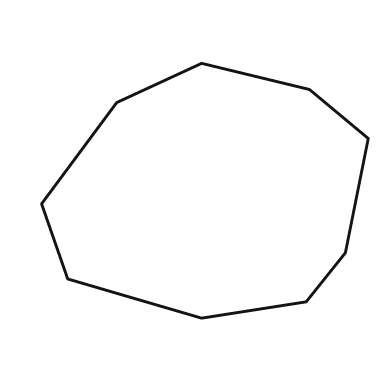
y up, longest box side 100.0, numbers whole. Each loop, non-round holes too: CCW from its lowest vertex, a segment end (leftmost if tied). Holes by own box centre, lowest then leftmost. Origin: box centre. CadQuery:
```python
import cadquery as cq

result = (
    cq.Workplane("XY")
    .moveTo(-1.0, -39.0)
    .lineTo(31.0, -34.0)
    .lineTo(43.0, -19.0)
    .lineTo(50.0, 16.0)
    .lineTo(32.0, 31.0)
    .lineTo(-1.0, 39.0)
    .lineTo(-27.0, 27.0)
    .lineTo(-50.0, -4.0)
    .lineTo(-42.0, -27.0)
    .close()
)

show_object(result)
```